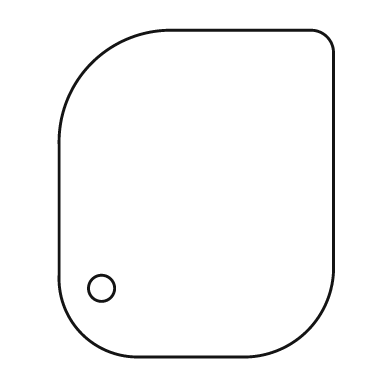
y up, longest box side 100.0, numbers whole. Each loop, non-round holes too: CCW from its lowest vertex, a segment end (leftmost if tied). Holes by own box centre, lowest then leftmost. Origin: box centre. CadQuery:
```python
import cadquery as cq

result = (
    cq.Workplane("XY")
    .moveTo(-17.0, -50.0)
    .lineTo(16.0, -50.0)
    .threePointArc((34.0, -42.0), (42.0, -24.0))
    .lineTo(42.0, 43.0)
    .threePointArc((40.0, 48.0), (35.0, 50.0))
    .lineTo(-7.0, 50.0)
    .threePointArc((-32.0, 40.0), (-42.0, 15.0))
    .lineTo(-42.0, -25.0)
    .threePointArc((-35.0, -43.0), (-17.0, -50.0))
    .close()
    .moveTo(-29.0, -29.0)
    .circle(4.0)
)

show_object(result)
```